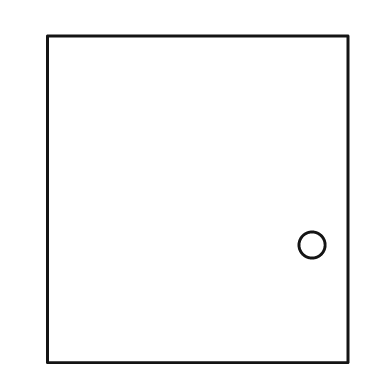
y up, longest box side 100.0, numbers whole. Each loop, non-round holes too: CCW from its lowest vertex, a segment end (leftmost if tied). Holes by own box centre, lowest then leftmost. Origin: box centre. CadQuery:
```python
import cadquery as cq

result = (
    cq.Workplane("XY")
    .moveTo(-46.0, -50.0)
    .lineTo(46.0, -50.0)
    .lineTo(46.0, 50.0)
    .lineTo(-46.0, 50.0)
    .close()
    .moveTo(35.0, -14.0)
    .circle(4.0)
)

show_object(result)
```